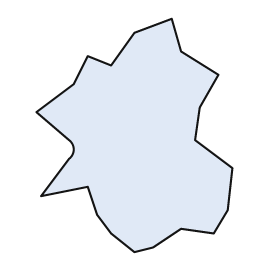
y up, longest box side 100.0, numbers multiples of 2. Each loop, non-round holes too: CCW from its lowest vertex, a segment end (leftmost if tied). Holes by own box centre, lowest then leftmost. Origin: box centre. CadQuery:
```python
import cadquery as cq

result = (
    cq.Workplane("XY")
    .moveTo(0.0, -50.0)
    .lineTo(8.0, -48.0)
    .lineTo(20.0, -40.0)
    .lineTo(34.0, -42.0)
    .lineTo(40.0, -32.0)
    .lineTo(42.0, -14.0)
    .lineTo(26.0, -2.0)
    .lineTo(28.0, 12.0)
    .lineTo(36.0, 26.0)
    .lineTo(20.0, 36.0)
    .lineTo(16.0, 50.0)
    .lineTo(0.0, 44.0)
    .lineTo(-10.0, 30.0)
    .lineTo(-20.0, 34.0)
    .lineTo(-26.0, 22.0)
    .lineTo(-42.0, 10.0)
    .lineTo(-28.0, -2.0)
    .threePointArc((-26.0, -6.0), (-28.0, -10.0))
    .lineTo(-40.0, -26.0)
    .lineTo(-20.0, -22.0)
    .lineTo(-16.0, -34.0)
    .lineTo(-10.0, -42.0)
    .close()
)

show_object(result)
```